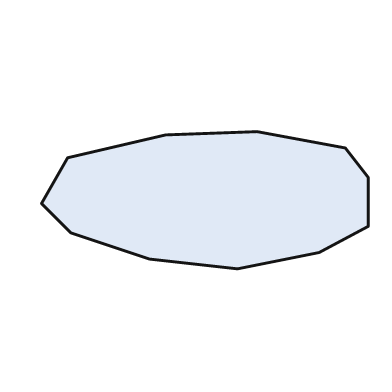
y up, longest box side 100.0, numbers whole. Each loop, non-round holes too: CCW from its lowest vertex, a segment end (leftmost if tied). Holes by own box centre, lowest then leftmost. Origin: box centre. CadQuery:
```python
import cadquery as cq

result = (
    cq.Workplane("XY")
    .moveTo(10.0, -21.0)
    .lineTo(35.0, -16.0)
    .lineTo(50.0, -8.0)
    .lineTo(50.0, 7.0)
    .lineTo(43.0, 16.0)
    .lineTo(16.0, 21.0)
    .lineTo(-12.0, 20.0)
    .lineTo(-42.0, 13.0)
    .lineTo(-50.0, -1.0)
    .lineTo(-41.0, -10.0)
    .lineTo(-17.0, -18.0)
    .close()
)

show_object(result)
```